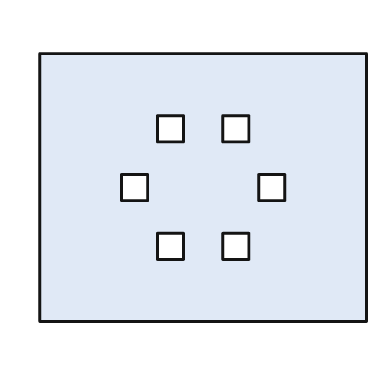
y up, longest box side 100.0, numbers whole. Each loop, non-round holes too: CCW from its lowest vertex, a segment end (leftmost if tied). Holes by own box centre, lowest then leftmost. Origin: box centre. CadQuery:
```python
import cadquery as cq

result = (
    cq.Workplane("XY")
    .moveTo(-50.0, -41.0)
    .lineTo(50.0, -41.0)
    .lineTo(50.0, 41.0)
    .lineTo(-50.0, 41.0)
    .close()
    .moveTo(-14.0, -22.0)
    .lineTo(-6.0, -22.0)
    .lineTo(-6.0, -14.0)
    .lineTo(-14.0, -14.0)
    .close()
    .moveTo(6.0, -22.0)
    .lineTo(14.0, -22.0)
    .lineTo(14.0, -14.0)
    .lineTo(6.0, -14.0)
    .close()
    .moveTo(-25.0, -4.0)
    .lineTo(-17.0, -4.0)
    .lineTo(-17.0, 4.0)
    .lineTo(-25.0, 4.0)
    .close()
    .moveTo(17.0, -4.0)
    .lineTo(25.0, -4.0)
    .lineTo(25.0, 4.0)
    .lineTo(17.0, 4.0)
    .close()
    .moveTo(-14.0, 14.0)
    .lineTo(-6.0, 14.0)
    .lineTo(-6.0, 22.0)
    .lineTo(-14.0, 22.0)
    .close()
    .moveTo(6.0, 14.0)
    .lineTo(14.0, 14.0)
    .lineTo(14.0, 22.0)
    .lineTo(6.0, 22.0)
    .close()
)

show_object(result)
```